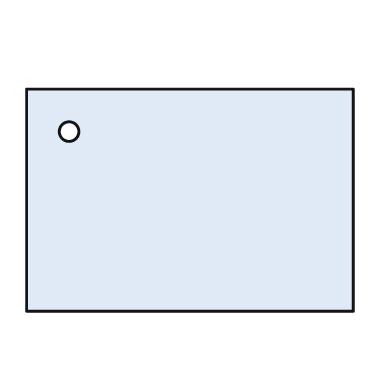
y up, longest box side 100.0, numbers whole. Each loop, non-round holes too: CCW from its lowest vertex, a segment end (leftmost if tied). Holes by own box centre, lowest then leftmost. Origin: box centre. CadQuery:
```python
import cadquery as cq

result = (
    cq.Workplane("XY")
    .moveTo(-50.0, -34.0)
    .lineTo(50.0, -34.0)
    .lineTo(50.0, 34.0)
    .lineTo(-50.0, 34.0)
    .close()
    .moveTo(-37.0, 21.0)
    .circle(3.0)
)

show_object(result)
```